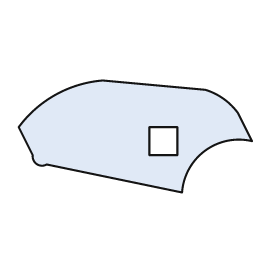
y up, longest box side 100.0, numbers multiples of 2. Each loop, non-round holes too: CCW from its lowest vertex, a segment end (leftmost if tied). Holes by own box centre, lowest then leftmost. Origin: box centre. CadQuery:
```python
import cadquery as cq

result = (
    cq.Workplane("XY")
    .moveTo(20.0, -24.0)
    .threePointArc((30.0, -6.0), (50.0, -2.0))
    .lineTo(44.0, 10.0)
    .threePointArc((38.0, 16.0), (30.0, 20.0))
    .lineTo(-14.0, 24.0)
    .threePointArc((-34.0, 18.0), (-50.0, 4.0))
    .lineTo(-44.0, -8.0)
    .threePointArc((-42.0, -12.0), (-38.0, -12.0))
    .close()
    .moveTo(6.0, -8.0)
    .lineTo(18.0, -8.0)
    .lineTo(18.0, 4.0)
    .lineTo(6.0, 4.0)
    .close()
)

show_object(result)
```